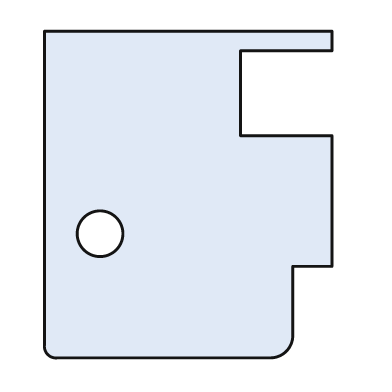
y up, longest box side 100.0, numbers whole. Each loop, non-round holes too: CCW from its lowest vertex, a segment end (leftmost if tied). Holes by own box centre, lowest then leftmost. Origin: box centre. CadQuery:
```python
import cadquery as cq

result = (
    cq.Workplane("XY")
    .moveTo(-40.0, -50.0)
    .lineTo(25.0, -50.0)
    .threePointArc((30.0, -48.0), (32.0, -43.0))
    .lineTo(32.0, -22.0)
    .lineTo(44.0, -22.0)
    .lineTo(44.0, 18.0)
    .lineTo(16.0, 18.0)
    .lineTo(16.0, 44.0)
    .lineTo(44.0, 44.0)
    .lineTo(44.0, 50.0)
    .lineTo(-44.0, 50.0)
    .lineTo(-44.0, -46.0)
    .threePointArc((-43.0, -49.0), (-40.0, -50.0))
    .close()
    .moveTo(-27.0, -12.0)
    .circle(7.0)
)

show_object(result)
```